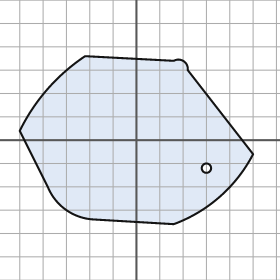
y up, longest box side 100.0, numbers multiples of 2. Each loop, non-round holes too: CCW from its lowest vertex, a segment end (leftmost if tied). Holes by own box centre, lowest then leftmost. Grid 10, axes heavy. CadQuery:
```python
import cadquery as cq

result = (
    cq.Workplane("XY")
    .moveTo(16.0, -36.0)
    .threePointArc((36.0, -24.0), (50.0, -6.0))
    .lineTo(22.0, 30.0)
    .threePointArc((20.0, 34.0), (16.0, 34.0))
    .lineTo(-22.0, 36.0)
    .threePointArc((-38.0, 22.0), (-50.0, 4.0))
    .lineTo(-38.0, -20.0)
    .threePointArc((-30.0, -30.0), (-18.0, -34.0))
    .close()
    .moveTo(30.0, -12.0)
    .circle(2.0)
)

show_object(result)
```